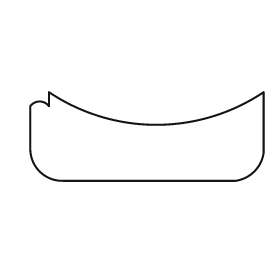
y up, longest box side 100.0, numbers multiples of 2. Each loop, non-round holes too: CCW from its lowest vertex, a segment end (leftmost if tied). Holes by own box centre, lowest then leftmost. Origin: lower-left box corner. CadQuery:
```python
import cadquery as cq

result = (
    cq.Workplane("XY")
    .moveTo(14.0, 0.0)
    .lineTo(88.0, 0.0)
    .threePointArc((96.0, 4.0), (100.0, 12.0))
    .lineTo(100.0, 38.0)
    .threePointArc((54.0, 24.0), (8.0, 38.0))
    .lineTo(8.0, 32.0)
    .threePointArc((4.0, 34.0), (0.0, 32.0))
    .lineTo(0.0, 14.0)
    .threePointArc((4.0, 4.0), (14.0, 0.0))
    .close()
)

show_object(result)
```